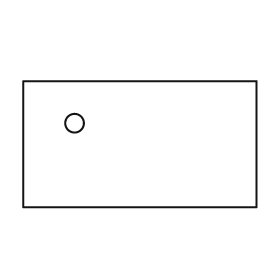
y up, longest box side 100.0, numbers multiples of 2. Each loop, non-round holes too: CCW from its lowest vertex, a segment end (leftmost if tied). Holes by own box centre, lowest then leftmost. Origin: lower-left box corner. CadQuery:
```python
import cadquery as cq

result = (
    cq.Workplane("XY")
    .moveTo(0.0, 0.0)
    .lineTo(100.0, 0.0)
    .lineTo(100.0, 54.0)
    .lineTo(0.0, 54.0)
    .close()
    .moveTo(22.0, 36.0)
    .circle(4.0)
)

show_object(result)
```